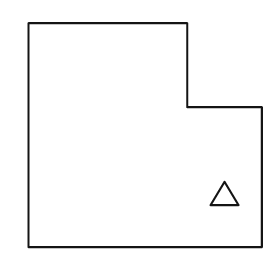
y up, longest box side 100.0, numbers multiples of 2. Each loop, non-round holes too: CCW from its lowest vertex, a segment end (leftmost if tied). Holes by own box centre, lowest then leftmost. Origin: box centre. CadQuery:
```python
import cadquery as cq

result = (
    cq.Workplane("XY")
    .moveTo(-50.0, -48.0)
    .lineTo(50.0, -48.0)
    .lineTo(50.0, 12.0)
    .lineTo(18.0, 12.0)
    .lineTo(18.0, 48.0)
    .lineTo(-50.0, 48.0)
    .close()
    .moveTo(28.0, -30.0)
    .lineTo(40.0, -30.0)
    .lineTo(34.0, -20.0)
    .close()
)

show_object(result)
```